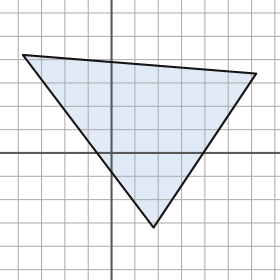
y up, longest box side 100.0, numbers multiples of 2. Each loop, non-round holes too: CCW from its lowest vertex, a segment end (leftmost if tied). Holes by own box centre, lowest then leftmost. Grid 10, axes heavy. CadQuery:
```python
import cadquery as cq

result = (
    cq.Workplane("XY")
    .moveTo(18.0, -32.0)
    .lineTo(62.0, 34.0)
    .lineTo(-38.0, 42.0)
    .close()
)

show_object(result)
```